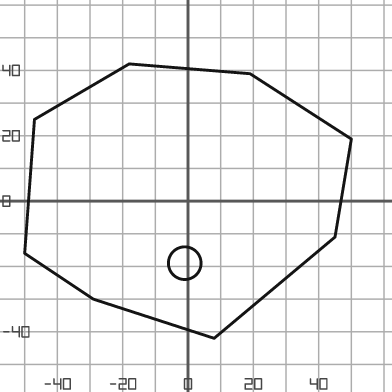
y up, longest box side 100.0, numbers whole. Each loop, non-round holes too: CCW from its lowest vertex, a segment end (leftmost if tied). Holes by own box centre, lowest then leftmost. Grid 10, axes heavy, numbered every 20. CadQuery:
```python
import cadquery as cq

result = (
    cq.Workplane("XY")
    .moveTo(8.0, -42.0)
    .lineTo(45.0, -11.0)
    .lineTo(50.0, 19.0)
    .lineTo(19.0, 39.0)
    .lineTo(-18.0, 42.0)
    .lineTo(-47.0, 25.0)
    .lineTo(-50.0, -16.0)
    .lineTo(-29.0, -30.0)
    .close()
    .moveTo(-1.0, -19.0)
    .circle(5.0)
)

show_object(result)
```